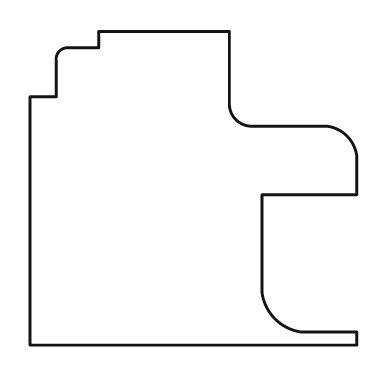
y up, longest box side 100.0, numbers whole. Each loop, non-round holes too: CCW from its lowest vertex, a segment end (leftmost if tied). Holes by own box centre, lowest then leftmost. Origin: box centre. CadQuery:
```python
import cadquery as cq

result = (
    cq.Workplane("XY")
    .moveTo(-50.0, -48.0)
    .lineTo(50.0, -48.0)
    .lineTo(50.0, -44.0)
    .lineTo(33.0, -44.0)
    .threePointArc((25.0, -40.0), (21.0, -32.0))
    .lineTo(21.0, -2.0)
    .lineTo(50.0, -2.0)
    .lineTo(50.0, 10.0)
    .threePointArc((47.0, 16.0), (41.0, 19.0))
    .lineTo(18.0, 19.0)
    .threePointArc((13.0, 21.0), (11.0, 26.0))
    .lineTo(11.0, 48.0)
    .lineTo(-29.0, 48.0)
    .lineTo(-29.0, 43.0)
    .lineTo(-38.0, 43.0)
    .threePointArc((-41.0, 42.0), (-42.0, 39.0))
    .lineTo(-42.0, 28.0)
    .lineTo(-50.0, 28.0)
    .close()
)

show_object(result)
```